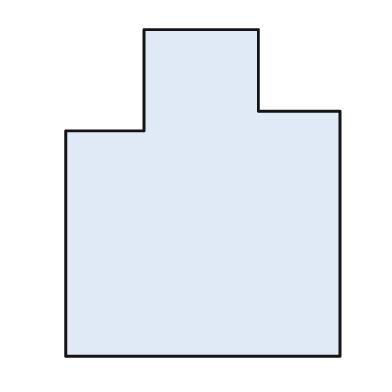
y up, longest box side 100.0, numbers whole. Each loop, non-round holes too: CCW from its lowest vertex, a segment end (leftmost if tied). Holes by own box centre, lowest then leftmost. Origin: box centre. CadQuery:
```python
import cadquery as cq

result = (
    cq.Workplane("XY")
    .moveTo(-42.0, -50.0)
    .lineTo(42.0, -50.0)
    .lineTo(42.0, 25.0)
    .lineTo(17.0, 25.0)
    .lineTo(17.0, 50.0)
    .lineTo(-18.0, 50.0)
    .lineTo(-18.0, 19.0)
    .lineTo(-42.0, 19.0)
    .close()
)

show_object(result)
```